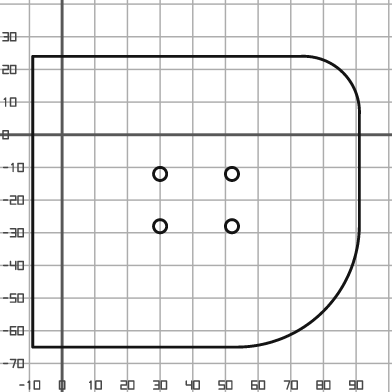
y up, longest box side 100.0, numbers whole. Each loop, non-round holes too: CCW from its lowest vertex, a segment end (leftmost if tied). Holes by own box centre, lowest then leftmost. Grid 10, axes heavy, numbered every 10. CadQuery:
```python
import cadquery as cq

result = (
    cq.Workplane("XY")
    .moveTo(-9.0, -65.0)
    .lineTo(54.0, -65.0)
    .threePointArc((80.0, -54.0), (91.0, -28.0))
    .lineTo(91.0, 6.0)
    .threePointArc((86.0, 19.0), (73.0, 24.0))
    .lineTo(-9.0, 24.0)
    .close()
    .moveTo(30.0, -28.0)
    .circle(2.0)
    .moveTo(52.0, -28.0)
    .circle(2.0)
    .moveTo(30.0, -12.0)
    .circle(2.0)
    .moveTo(52.0, -12.0)
    .circle(2.0)
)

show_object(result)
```